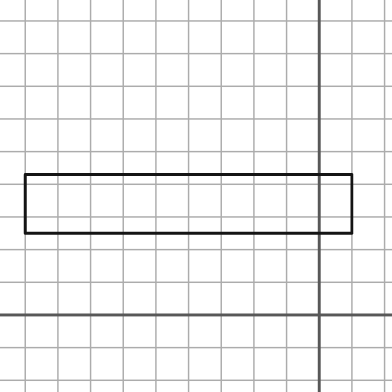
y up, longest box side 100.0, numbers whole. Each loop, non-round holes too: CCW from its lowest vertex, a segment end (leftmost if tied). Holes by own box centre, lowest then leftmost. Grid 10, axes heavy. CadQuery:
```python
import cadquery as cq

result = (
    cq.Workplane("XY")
    .moveTo(-90.0, 25.0)
    .lineTo(10.0, 25.0)
    .lineTo(10.0, 43.0)
    .lineTo(-90.0, 43.0)
    .close()
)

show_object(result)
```